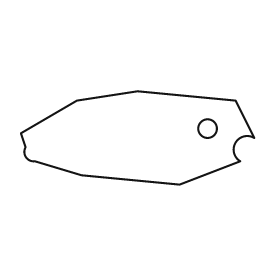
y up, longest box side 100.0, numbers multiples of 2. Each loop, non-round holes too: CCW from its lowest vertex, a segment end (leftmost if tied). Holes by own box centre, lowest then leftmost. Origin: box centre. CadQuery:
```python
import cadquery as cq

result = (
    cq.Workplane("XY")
    .moveTo(18.0, -20.0)
    .lineTo(44.0, -10.0)
    .threePointArc((42.0, -2.0), (50.0, 0.0))
    .lineTo(42.0, 16.0)
    .lineTo(0.0, 20.0)
    .lineTo(-26.0, 16.0)
    .lineTo(-50.0, 2.0)
    .lineTo(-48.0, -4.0)
    .threePointArc((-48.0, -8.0), (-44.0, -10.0))
    .lineTo(-24.0, -16.0)
    .close()
    .moveTo(30.0, 4.0)
    .circle(4.0)
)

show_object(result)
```